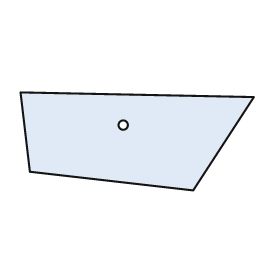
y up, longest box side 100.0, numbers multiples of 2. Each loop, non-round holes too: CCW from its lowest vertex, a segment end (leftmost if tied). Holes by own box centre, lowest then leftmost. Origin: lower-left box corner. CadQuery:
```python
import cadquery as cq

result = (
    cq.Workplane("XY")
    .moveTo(74.0, 0.0)
    .lineTo(100.0, 40.0)
    .lineTo(0.0, 42.0)
    .lineTo(4.0, 8.0)
    .close()
    .moveTo(44.0, 28.0)
    .circle(2.0)
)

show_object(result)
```